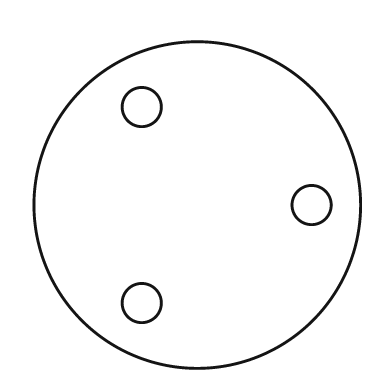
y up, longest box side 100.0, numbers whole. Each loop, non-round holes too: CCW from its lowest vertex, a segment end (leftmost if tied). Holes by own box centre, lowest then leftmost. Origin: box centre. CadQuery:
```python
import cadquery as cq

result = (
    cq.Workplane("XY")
    .moveTo(0.0, 0.0)
    .circle(50.0)
    .moveTo(-17.0, -30.0)
    .circle(6.0)
    .moveTo(35.0, 0.0)
    .circle(6.0)
    .moveTo(-17.0, 30.0)
    .circle(6.0)
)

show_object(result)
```